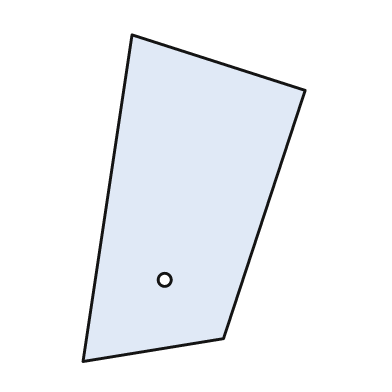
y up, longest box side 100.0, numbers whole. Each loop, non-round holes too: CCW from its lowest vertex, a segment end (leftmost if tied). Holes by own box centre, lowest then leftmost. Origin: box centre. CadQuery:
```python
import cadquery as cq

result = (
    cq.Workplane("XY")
    .moveTo(-34.0, -50.0)
    .lineTo(9.0, -43.0)
    .lineTo(34.0, 33.0)
    .lineTo(-19.0, 50.0)
    .close()
    .moveTo(-9.0, -25.0)
    .circle(2.0)
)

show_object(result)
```